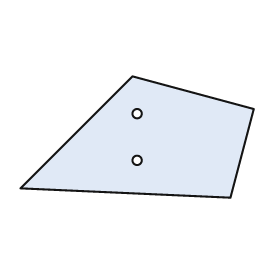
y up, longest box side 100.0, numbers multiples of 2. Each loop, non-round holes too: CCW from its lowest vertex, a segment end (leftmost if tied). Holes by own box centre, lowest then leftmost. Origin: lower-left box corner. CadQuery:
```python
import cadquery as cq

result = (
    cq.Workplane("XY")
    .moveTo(90.0, 0.0)
    .lineTo(100.0, 38.0)
    .lineTo(48.0, 52.0)
    .lineTo(0.0, 4.0)
    .close()
    .moveTo(50.0, 16.0)
    .circle(2.0)
    .moveTo(50.0, 36.0)
    .circle(2.0)
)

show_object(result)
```